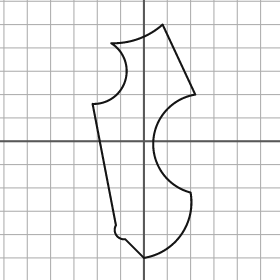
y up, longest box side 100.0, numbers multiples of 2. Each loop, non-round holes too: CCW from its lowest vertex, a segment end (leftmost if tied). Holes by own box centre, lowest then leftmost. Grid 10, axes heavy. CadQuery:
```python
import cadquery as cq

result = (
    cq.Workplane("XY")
    .moveTo(0.0, -50.0)
    .threePointArc((16.0, -40.0), (20.0, -22.0))
    .threePointArc((4.0, 0.0), (22.0, 20.0))
    .lineTo(8.0, 50.0)
    .threePointArc((-2.0, 44.0), (-14.0, 42.0))
    .threePointArc((-8.0, 26.0), (-22.0, 16.0))
    .lineTo(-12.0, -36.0)
    .threePointArc((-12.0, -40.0), (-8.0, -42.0))
    .close()
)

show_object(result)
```